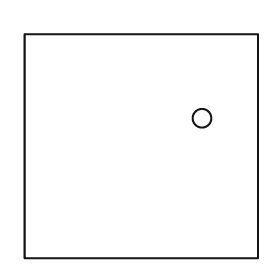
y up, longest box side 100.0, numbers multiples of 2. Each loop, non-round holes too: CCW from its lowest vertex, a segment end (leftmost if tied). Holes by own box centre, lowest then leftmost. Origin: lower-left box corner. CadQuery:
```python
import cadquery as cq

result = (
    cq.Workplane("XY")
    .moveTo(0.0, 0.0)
    .lineTo(100.0, 0.0)
    .lineTo(100.0, 96.0)
    .lineTo(0.0, 96.0)
    .close()
    .moveTo(76.0, 60.0)
    .circle(4.0)
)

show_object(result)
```